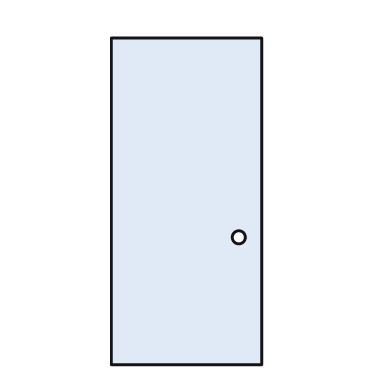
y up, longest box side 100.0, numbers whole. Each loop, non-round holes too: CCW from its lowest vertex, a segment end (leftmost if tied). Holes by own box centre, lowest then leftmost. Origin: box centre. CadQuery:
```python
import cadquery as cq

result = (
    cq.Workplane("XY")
    .moveTo(-23.0, -50.0)
    .lineTo(23.0, -50.0)
    .lineTo(23.0, 50.0)
    .lineTo(-23.0, 50.0)
    .close()
    .moveTo(16.0, -11.0)
    .circle(2.0)
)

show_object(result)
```